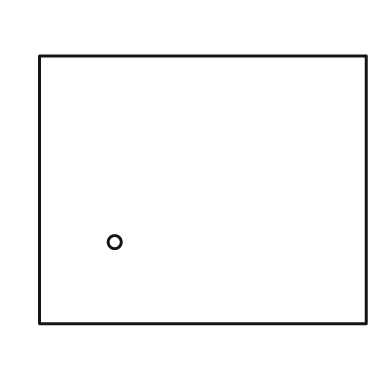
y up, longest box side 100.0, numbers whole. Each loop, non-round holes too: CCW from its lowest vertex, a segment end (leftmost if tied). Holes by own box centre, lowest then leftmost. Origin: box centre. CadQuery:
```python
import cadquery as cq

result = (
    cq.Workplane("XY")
    .moveTo(-50.0, -41.0)
    .lineTo(50.0, -41.0)
    .lineTo(50.0, 41.0)
    .lineTo(-50.0, 41.0)
    .close()
    .moveTo(-27.0, -16.0)
    .circle(2.0)
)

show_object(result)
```